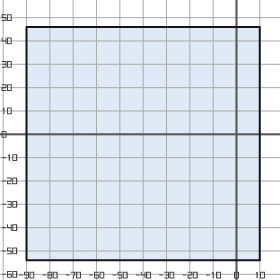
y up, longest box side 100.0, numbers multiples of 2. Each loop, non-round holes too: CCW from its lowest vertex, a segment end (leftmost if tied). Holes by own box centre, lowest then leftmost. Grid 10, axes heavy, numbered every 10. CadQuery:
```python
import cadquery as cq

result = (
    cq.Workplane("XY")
    .moveTo(-90.0, -54.0)
    .lineTo(10.0, -54.0)
    .lineTo(10.0, 46.0)
    .lineTo(-90.0, 46.0)
    .close()
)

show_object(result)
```